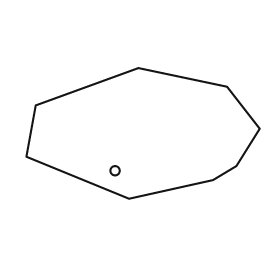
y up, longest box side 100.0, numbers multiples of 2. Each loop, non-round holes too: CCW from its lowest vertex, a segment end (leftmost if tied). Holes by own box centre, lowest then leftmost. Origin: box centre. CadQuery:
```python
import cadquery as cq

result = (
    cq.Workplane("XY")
    .moveTo(-6.0, -28.0)
    .lineTo(30.0, -20.0)
    .lineTo(40.0, -14.0)
    .lineTo(50.0, 2.0)
    .lineTo(36.0, 20.0)
    .lineTo(-2.0, 28.0)
    .lineTo(-46.0, 12.0)
    .lineTo(-50.0, -10.0)
    .close()
    .moveTo(-12.0, -16.0)
    .circle(2.0)
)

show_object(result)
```